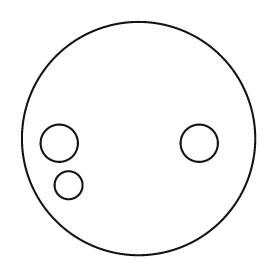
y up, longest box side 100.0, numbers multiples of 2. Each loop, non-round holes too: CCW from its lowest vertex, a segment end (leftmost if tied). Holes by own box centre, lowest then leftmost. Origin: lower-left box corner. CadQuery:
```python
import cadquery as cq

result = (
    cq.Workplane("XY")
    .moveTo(50.0, 50.0)
    .circle(50.0)
    .moveTo(20.0, 30.0)
    .circle(6.0)
    .moveTo(16.0, 48.0)
    .circle(8.0)
    .moveTo(76.0, 48.0)
    .circle(8.0)
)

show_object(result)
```